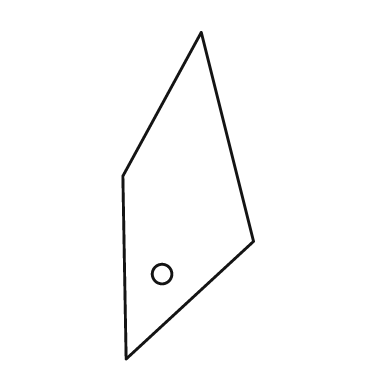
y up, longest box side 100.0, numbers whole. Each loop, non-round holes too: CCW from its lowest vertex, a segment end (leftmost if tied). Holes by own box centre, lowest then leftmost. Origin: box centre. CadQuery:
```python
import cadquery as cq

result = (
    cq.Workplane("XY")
    .moveTo(-19.0, -50.0)
    .lineTo(20.0, -14.0)
    .lineTo(4.0, 50.0)
    .lineTo(-20.0, 6.0)
    .close()
    .moveTo(-8.0, -24.0)
    .circle(3.0)
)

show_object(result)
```